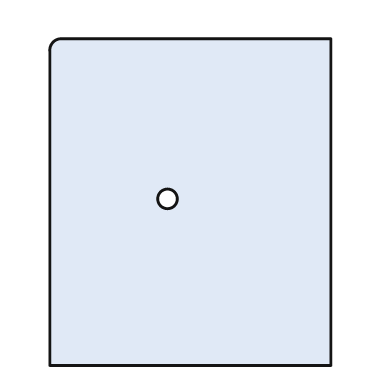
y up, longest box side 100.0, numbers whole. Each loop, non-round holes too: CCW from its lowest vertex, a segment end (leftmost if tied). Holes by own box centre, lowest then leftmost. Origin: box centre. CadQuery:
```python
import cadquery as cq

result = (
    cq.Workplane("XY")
    .moveTo(-43.0, -50.0)
    .lineTo(43.0, -50.0)
    .lineTo(43.0, 50.0)
    .lineTo(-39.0, 50.0)
    .threePointArc((-42.0, 49.0), (-43.0, 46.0))
    .close()
    .moveTo(-7.0, 1.0)
    .circle(3.0)
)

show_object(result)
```